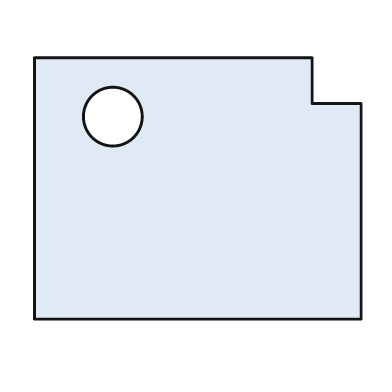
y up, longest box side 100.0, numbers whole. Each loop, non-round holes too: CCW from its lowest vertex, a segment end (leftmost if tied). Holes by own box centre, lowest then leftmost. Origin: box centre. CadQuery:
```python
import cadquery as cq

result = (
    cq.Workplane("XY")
    .moveTo(-50.0, -40.0)
    .lineTo(50.0, -40.0)
    .lineTo(50.0, 26.0)
    .lineTo(35.0, 26.0)
    .lineTo(35.0, 40.0)
    .lineTo(-50.0, 40.0)
    .close()
    .moveTo(-26.0, 22.0)
    .circle(9.0)
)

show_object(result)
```